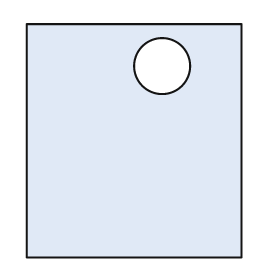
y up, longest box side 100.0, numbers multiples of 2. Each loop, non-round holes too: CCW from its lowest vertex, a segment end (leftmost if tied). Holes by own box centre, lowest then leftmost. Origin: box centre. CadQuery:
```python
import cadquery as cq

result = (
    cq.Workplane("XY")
    .moveTo(-46.0, -50.0)
    .lineTo(46.0, -50.0)
    .lineTo(46.0, 50.0)
    .lineTo(-46.0, 50.0)
    .close()
    .moveTo(12.0, 32.0)
    .circle(12.0)
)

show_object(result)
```